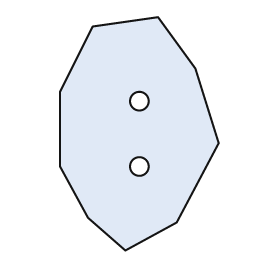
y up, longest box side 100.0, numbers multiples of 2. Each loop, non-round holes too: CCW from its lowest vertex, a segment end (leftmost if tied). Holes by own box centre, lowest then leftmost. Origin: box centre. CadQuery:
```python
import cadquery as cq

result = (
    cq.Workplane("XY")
    .moveTo(-6.0, -50.0)
    .lineTo(16.0, -38.0)
    .lineTo(34.0, -4.0)
    .lineTo(24.0, 28.0)
    .lineTo(8.0, 50.0)
    .lineTo(-20.0, 46.0)
    .lineTo(-34.0, 18.0)
    .lineTo(-34.0, -14.0)
    .lineTo(-22.0, -36.0)
    .close()
    .moveTo(0.0, -14.0)
    .circle(4.0)
    .moveTo(0.0, 14.0)
    .circle(4.0)
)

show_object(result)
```